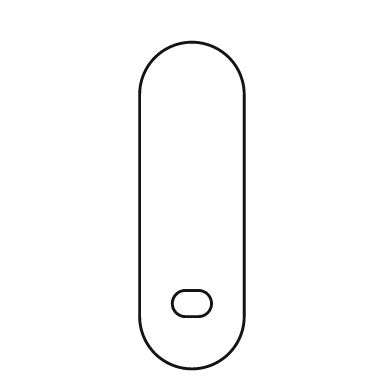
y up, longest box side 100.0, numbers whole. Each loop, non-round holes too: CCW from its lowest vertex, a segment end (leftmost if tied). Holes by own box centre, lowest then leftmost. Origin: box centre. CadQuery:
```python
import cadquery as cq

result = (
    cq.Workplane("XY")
    .moveTo(-16.0, -34.0)
    .threePointArc((0.0, -50.0), (16.0, -34.0))
    .lineTo(16.0, 34.0)
    .threePointArc((0.0, 50.0), (-16.0, 34.0))
    .close()
    .moveTo(-2.0, -34.0)
    .lineTo(2.0, -34.0)
    .threePointArc((6.0, -30.0), (2.0, -26.0))
    .lineTo(-2.0, -26.0)
    .threePointArc((-6.0, -30.0), (-2.0, -34.0))
    .close()
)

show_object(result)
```